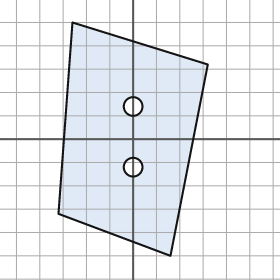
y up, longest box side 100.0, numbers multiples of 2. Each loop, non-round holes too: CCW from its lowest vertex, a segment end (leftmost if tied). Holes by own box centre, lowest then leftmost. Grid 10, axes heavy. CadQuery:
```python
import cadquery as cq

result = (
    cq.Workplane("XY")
    .moveTo(16.0, -50.0)
    .lineTo(32.0, 32.0)
    .lineTo(-26.0, 50.0)
    .lineTo(-32.0, -32.0)
    .close()
    .moveTo(0.0, -12.0)
    .circle(4.0)
    .moveTo(0.0, 14.0)
    .circle(4.0)
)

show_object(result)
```